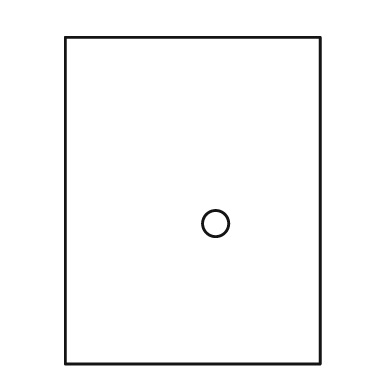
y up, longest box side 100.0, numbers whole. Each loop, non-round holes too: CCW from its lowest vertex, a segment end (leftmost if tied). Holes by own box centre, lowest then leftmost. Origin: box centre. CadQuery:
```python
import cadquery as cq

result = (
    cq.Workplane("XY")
    .moveTo(-39.0, -50.0)
    .lineTo(39.0, -50.0)
    .lineTo(39.0, 50.0)
    .lineTo(-39.0, 50.0)
    .close()
    .moveTo(7.0, -7.0)
    .circle(4.0)
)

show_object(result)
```